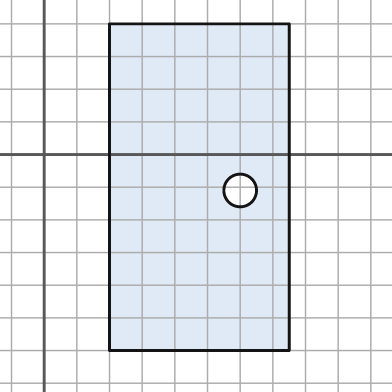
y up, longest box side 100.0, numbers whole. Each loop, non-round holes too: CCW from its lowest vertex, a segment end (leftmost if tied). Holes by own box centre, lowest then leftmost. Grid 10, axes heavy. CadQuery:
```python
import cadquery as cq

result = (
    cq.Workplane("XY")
    .moveTo(20.0, -60.0)
    .lineTo(75.0, -60.0)
    .lineTo(75.0, 40.0)
    .lineTo(20.0, 40.0)
    .close()
    .moveTo(60.0, -11.0)
    .circle(5.0)
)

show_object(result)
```